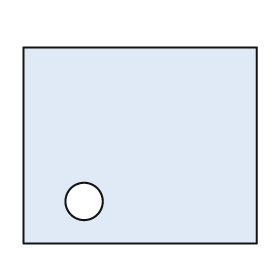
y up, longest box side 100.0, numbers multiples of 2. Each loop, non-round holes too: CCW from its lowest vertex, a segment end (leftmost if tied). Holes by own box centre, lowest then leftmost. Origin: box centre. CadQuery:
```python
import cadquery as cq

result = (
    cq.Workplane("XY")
    .moveTo(-50.0, -42.0)
    .lineTo(50.0, -42.0)
    .lineTo(50.0, 42.0)
    .lineTo(-50.0, 42.0)
    .close()
    .moveTo(-24.0, -24.0)
    .circle(8.0)
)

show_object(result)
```